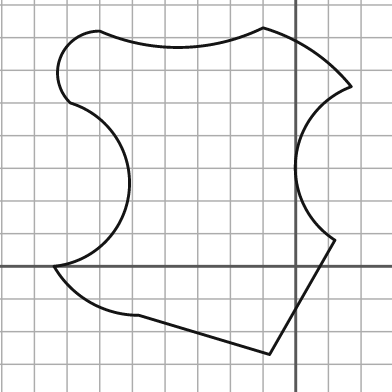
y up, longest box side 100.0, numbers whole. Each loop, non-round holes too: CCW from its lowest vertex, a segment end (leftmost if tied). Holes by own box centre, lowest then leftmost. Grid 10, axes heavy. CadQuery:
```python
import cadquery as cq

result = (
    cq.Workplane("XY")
    .moveTo(-8.0, -27.0)
    .lineTo(12.0, 8.0)
    .threePointArc((0.0, 33.0), (17.0, 55.0))
    .threePointArc((5.0, 66.0), (-10.0, 73.0))
    .threePointArc((-35.0, 67.0), (-60.0, 72.0))
    .threePointArc((-72.0, 64.0), (-69.0, 50.0))
    .threePointArc((-51.0, 23.0), (-74.0, 0.0))
    .threePointArc((-63.0, -11.0), (-48.0, -15.0))
    .close()
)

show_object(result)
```